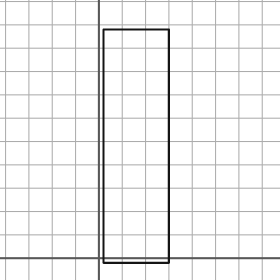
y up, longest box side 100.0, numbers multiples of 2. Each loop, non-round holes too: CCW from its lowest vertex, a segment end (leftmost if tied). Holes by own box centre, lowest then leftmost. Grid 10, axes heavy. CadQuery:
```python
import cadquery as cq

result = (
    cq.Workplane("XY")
    .moveTo(2.0, -2.0)
    .lineTo(30.0, -2.0)
    .lineTo(30.0, 98.0)
    .lineTo(2.0, 98.0)
    .close()
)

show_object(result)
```